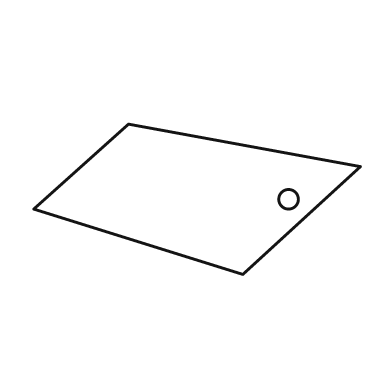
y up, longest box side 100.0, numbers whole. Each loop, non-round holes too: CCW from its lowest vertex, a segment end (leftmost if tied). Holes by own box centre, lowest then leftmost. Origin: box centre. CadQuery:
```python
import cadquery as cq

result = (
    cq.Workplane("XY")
    .moveTo(14.0, -23.0)
    .lineTo(50.0, 10.0)
    .lineTo(-21.0, 23.0)
    .lineTo(-50.0, -3.0)
    .close()
    .moveTo(28.0, 0.0)
    .circle(3.0)
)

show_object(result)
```